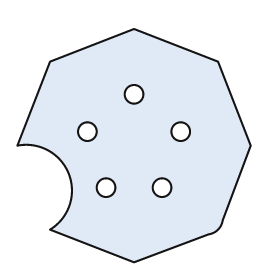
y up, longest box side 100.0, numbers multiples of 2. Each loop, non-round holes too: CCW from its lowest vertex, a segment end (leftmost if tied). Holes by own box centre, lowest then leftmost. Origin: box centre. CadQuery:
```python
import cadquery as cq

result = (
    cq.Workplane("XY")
    .moveTo(0.0, -50.0)
    .lineTo(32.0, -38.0)
    .threePointArc((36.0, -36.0), (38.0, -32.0))
    .lineTo(50.0, 0.0)
    .lineTo(36.0, 36.0)
    .lineTo(0.0, 50.0)
    .lineTo(-36.0, 36.0)
    .lineTo(-50.0, 0.0)
    .threePointArc((-28.0, -12.0), (-36.0, -36.0))
    .close()
    .moveTo(-12.0, -18.0)
    .circle(4.0)
    .moveTo(12.0, -18.0)
    .circle(4.0)
    .moveTo(-20.0, 6.0)
    .circle(4.0)
    .moveTo(20.0, 6.0)
    .circle(4.0)
    .moveTo(0.0, 22.0)
    .circle(4.0)
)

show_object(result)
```